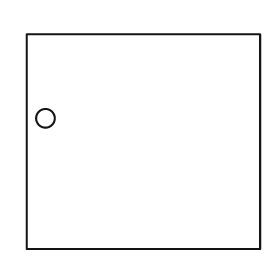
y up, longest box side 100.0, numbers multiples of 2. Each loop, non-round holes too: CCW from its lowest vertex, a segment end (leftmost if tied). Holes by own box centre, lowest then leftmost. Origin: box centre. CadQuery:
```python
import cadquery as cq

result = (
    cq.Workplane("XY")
    .moveTo(-50.0, -46.0)
    .lineTo(50.0, -46.0)
    .lineTo(50.0, 46.0)
    .lineTo(-50.0, 46.0)
    .close()
    .moveTo(-42.0, 10.0)
    .circle(4.0)
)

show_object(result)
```